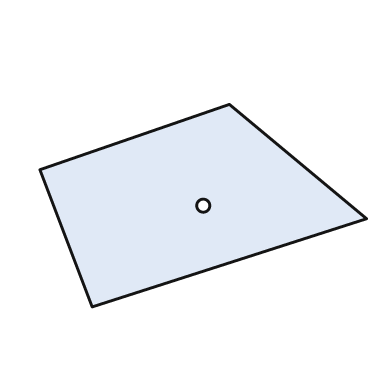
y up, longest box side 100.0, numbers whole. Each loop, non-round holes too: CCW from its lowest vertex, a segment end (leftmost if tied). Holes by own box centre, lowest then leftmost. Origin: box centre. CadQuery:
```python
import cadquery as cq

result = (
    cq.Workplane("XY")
    .moveTo(-34.0, -31.0)
    .lineTo(50.0, -4.0)
    .lineTo(8.0, 31.0)
    .lineTo(-50.0, 11.0)
    .close()
    .moveTo(0.0, 0.0)
    .circle(2.0)
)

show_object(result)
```